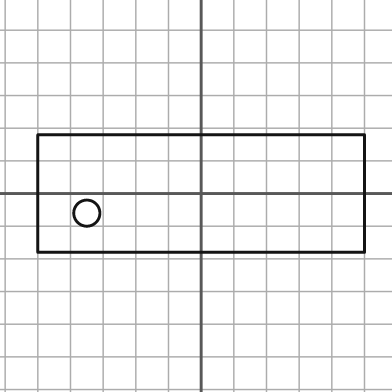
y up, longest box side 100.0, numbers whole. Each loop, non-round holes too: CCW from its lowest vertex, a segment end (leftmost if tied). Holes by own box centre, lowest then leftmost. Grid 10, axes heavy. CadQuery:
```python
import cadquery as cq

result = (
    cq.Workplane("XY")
    .moveTo(-50.0, -18.0)
    .lineTo(50.0, -18.0)
    .lineTo(50.0, 18.0)
    .lineTo(-50.0, 18.0)
    .close()
    .moveTo(-35.0, -6.0)
    .circle(4.0)
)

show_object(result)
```